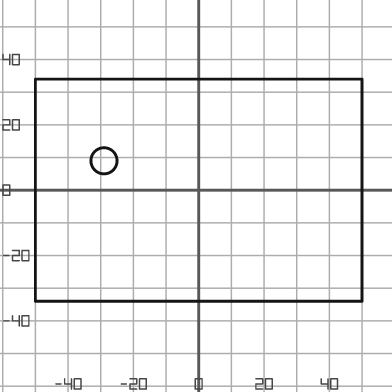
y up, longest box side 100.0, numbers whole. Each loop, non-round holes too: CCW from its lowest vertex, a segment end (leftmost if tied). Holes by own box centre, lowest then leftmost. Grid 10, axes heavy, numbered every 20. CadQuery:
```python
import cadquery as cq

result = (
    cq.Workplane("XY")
    .moveTo(-50.0, -34.0)
    .lineTo(50.0, -34.0)
    .lineTo(50.0, 34.0)
    .lineTo(-50.0, 34.0)
    .close()
    .moveTo(-29.0, 9.0)
    .circle(4.0)
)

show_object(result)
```